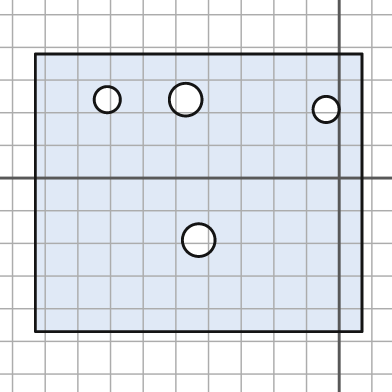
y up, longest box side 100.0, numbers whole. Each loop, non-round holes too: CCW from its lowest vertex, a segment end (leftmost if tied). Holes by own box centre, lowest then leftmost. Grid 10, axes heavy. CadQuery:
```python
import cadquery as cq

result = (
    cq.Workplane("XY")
    .moveTo(-93.0, -47.0)
    .lineTo(7.0, -47.0)
    .lineTo(7.0, 38.0)
    .lineTo(-93.0, 38.0)
    .close()
    .moveTo(-43.0, -19.0)
    .circle(5.0)
    .moveTo(-4.0, 21.0)
    .circle(4.0)
    .moveTo(-71.0, 24.0)
    .circle(4.0)
    .moveTo(-47.0, 24.0)
    .circle(5.0)
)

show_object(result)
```